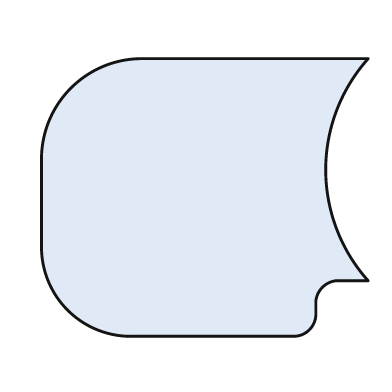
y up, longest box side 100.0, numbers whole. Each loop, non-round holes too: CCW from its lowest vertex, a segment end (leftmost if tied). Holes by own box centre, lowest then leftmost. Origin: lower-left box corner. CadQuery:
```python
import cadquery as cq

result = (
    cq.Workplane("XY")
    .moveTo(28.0, 0.0)
    .lineTo(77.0, 0.0)
    .threePointArc((82.0, 2.0), (84.0, 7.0))
    .lineTo(84.0, 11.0)
    .threePointArc((86.0, 15.0), (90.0, 17.0))
    .lineTo(100.0, 17.0)
    .threePointArc((87.0, 51.0), (100.0, 85.0))
    .lineTo(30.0, 85.0)
    .threePointArc((9.0, 76.0), (0.0, 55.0))
    .lineTo(0.0, 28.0)
    .threePointArc((8.0, 8.0), (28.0, 0.0))
    .close()
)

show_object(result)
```